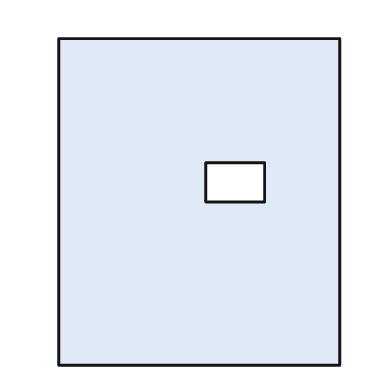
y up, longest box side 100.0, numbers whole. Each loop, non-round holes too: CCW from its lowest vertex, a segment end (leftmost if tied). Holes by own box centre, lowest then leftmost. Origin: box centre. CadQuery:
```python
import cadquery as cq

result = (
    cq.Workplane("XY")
    .moveTo(-43.0, -50.0)
    .lineTo(43.0, -50.0)
    .lineTo(43.0, 50.0)
    .lineTo(-43.0, 50.0)
    .close()
    .moveTo(2.0, 0.0)
    .lineTo(20.0, 0.0)
    .lineTo(20.0, 12.0)
    .lineTo(2.0, 12.0)
    .close()
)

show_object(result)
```